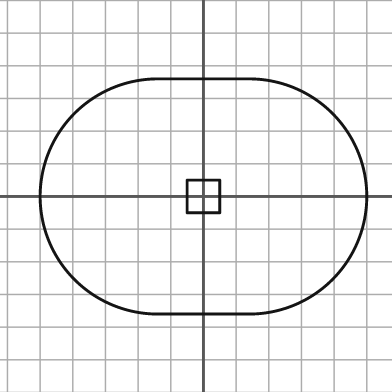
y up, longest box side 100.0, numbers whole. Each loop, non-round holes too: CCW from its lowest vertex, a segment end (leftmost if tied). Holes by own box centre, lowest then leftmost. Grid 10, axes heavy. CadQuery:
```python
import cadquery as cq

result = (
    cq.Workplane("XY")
    .moveTo(-14.0, -36.0)
    .lineTo(14.0, -36.0)
    .threePointArc((50.0, 0.0), (14.0, 36.0))
    .lineTo(-14.0, 36.0)
    .threePointArc((-50.0, 0.0), (-14.0, -36.0))
    .close()
    .moveTo(-5.0, -5.0)
    .lineTo(5.0, -5.0)
    .lineTo(5.0, 5.0)
    .lineTo(-5.0, 5.0)
    .close()
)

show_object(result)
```